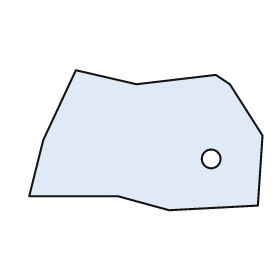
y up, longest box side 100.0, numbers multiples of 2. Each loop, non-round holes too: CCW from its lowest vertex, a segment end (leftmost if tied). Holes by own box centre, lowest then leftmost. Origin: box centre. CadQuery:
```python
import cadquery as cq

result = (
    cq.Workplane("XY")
    .moveTo(10.0, -30.0)
    .lineTo(48.0, -28.0)
    .lineTo(50.0, 2.0)
    .lineTo(36.0, 24.0)
    .lineTo(30.0, 28.0)
    .lineTo(-4.0, 24.0)
    .lineTo(-30.0, 30.0)
    .lineTo(-44.0, 0.0)
    .lineTo(-50.0, -24.0)
    .lineTo(-12.0, -24.0)
    .close()
    .moveTo(28.0, -8.0)
    .circle(4.0)
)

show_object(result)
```